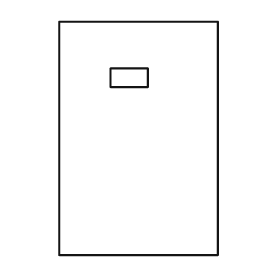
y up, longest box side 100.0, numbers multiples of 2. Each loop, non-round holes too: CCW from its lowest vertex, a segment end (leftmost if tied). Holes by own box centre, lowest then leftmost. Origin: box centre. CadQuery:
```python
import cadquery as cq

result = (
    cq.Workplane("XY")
    .moveTo(-34.0, -50.0)
    .lineTo(34.0, -50.0)
    .lineTo(34.0, 50.0)
    .lineTo(-34.0, 50.0)
    .close()
    .moveTo(-12.0, 22.0)
    .lineTo(4.0, 22.0)
    .lineTo(4.0, 30.0)
    .lineTo(-12.0, 30.0)
    .close()
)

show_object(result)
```